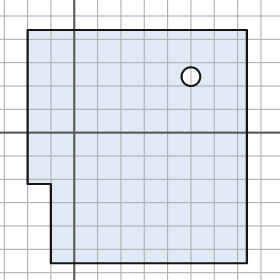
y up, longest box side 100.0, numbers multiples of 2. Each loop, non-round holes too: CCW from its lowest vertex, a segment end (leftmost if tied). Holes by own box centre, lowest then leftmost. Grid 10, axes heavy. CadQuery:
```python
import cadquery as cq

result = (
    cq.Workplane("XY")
    .moveTo(-10.0, -56.0)
    .lineTo(74.0, -56.0)
    .lineTo(74.0, 44.0)
    .lineTo(-20.0, 44.0)
    .lineTo(-20.0, -22.0)
    .lineTo(-10.0, -22.0)
    .close()
    .moveTo(50.0, 24.0)
    .circle(4.0)
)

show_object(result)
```